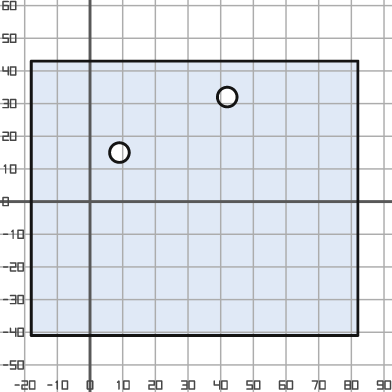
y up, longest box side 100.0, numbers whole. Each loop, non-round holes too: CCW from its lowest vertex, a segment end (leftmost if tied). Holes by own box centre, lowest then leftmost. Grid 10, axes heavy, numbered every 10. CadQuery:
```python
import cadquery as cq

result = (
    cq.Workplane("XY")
    .moveTo(-18.0, -41.0)
    .lineTo(82.0, -41.0)
    .lineTo(82.0, 43.0)
    .lineTo(-18.0, 43.0)
    .close()
    .moveTo(9.0, 15.0)
    .circle(3.0)
    .moveTo(42.0, 32.0)
    .circle(3.0)
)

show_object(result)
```